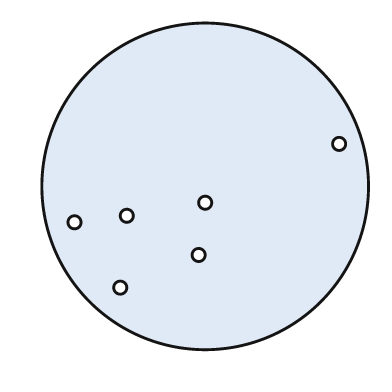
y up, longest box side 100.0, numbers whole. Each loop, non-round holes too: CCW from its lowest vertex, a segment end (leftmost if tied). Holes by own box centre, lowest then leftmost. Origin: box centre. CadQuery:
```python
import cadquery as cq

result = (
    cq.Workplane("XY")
    .moveTo(0.0, 0.0)
    .circle(50.0)
    .moveTo(-26.0, -31.0)
    .circle(2.0)
    .moveTo(-2.0, -21.0)
    .circle(2.0)
    .moveTo(-40.0, -11.0)
    .circle(2.0)
    .moveTo(-24.0, -9.0)
    .circle(2.0)
    .moveTo(0.0, -5.0)
    .circle(2.0)
    .moveTo(41.0, 13.0)
    .circle(2.0)
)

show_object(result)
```